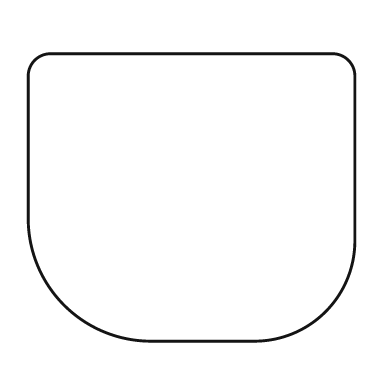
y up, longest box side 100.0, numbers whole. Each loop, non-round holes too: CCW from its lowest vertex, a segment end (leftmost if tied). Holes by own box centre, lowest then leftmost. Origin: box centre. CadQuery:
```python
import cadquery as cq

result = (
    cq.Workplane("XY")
    .moveTo(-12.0, -44.0)
    .lineTo(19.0, -44.0)
    .threePointArc((41.0, -35.0), (50.0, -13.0))
    .lineTo(50.0, 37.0)
    .threePointArc((48.0, 42.0), (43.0, 44.0))
    .lineTo(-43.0, 44.0)
    .threePointArc((-48.0, 42.0), (-50.0, 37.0))
    .lineTo(-50.0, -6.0)
    .threePointArc((-39.0, -33.0), (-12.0, -44.0))
    .close()
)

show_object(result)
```